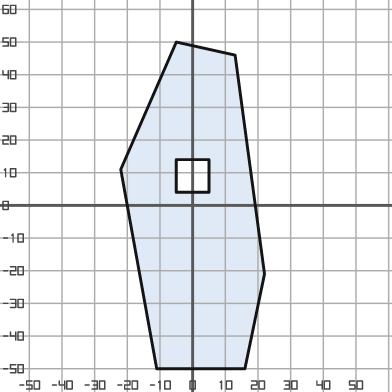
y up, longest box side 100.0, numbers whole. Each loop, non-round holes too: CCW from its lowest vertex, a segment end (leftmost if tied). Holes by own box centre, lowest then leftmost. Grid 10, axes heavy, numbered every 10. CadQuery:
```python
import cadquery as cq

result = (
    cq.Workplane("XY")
    .moveTo(-11.0, -50.0)
    .lineTo(16.0, -50.0)
    .lineTo(22.0, -21.0)
    .lineTo(13.0, 46.0)
    .lineTo(-5.0, 50.0)
    .lineTo(-22.0, 11.0)
    .close()
    .moveTo(-5.0, 4.0)
    .lineTo(5.0, 4.0)
    .lineTo(5.0, 14.0)
    .lineTo(-5.0, 14.0)
    .close()
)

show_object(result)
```